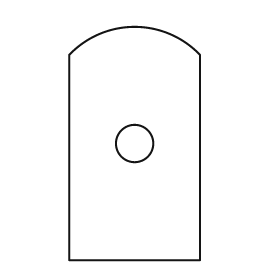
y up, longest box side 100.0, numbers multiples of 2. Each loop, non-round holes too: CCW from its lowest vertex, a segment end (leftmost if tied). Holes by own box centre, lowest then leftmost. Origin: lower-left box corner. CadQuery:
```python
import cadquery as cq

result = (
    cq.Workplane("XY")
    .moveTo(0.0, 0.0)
    .lineTo(56.0, 0.0)
    .lineTo(56.0, 88.0)
    .threePointArc((28.0, 100.0), (0.0, 88.0))
    .close()
    .moveTo(28.0, 50.0)
    .circle(8.0)
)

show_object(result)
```